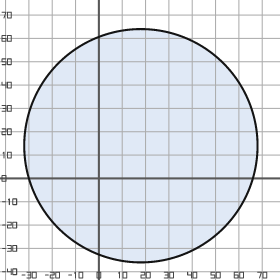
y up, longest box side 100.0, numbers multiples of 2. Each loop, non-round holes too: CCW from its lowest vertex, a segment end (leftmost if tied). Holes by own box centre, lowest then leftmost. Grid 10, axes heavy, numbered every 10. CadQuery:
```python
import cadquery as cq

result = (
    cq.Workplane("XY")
    .moveTo(18.0, 14.0)
    .circle(50.0)
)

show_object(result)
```